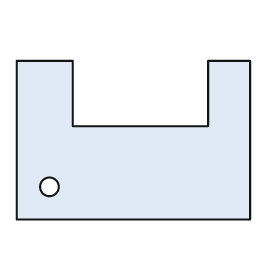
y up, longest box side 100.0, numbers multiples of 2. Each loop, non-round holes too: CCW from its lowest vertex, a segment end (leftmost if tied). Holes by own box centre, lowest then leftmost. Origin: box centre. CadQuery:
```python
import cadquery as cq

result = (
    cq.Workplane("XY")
    .moveTo(-50.0, -34.0)
    .lineTo(50.0, -34.0)
    .lineTo(50.0, 34.0)
    .lineTo(32.0, 34.0)
    .lineTo(32.0, 6.0)
    .lineTo(-26.0, 6.0)
    .lineTo(-26.0, 34.0)
    .lineTo(-50.0, 34.0)
    .close()
    .moveTo(-36.0, -20.0)
    .circle(4.0)
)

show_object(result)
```